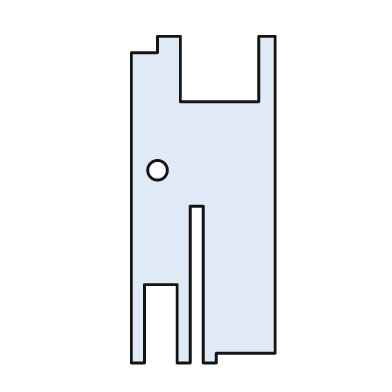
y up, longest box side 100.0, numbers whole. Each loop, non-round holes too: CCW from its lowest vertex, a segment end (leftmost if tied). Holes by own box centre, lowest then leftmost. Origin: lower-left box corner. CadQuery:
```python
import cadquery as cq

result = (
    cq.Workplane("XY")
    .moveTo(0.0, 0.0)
    .lineTo(4.0, 0.0)
    .lineTo(4.0, 24.0)
    .lineTo(14.0, 24.0)
    .lineTo(14.0, 0.0)
    .lineTo(18.0, 0.0)
    .lineTo(18.0, 48.0)
    .lineTo(22.0, 48.0)
    .lineTo(22.0, 0.0)
    .lineTo(26.0, 0.0)
    .lineTo(26.0, 3.0)
    .lineTo(44.0, 3.0)
    .lineTo(44.0, 100.0)
    .lineTo(39.0, 100.0)
    .lineTo(39.0, 80.0)
    .lineTo(15.0, 80.0)
    .lineTo(15.0, 100.0)
    .lineTo(8.0, 100.0)
    .lineTo(8.0, 95.0)
    .lineTo(0.0, 95.0)
    .close()
    .moveTo(8.0, 59.0)
    .circle(3.0)
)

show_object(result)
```